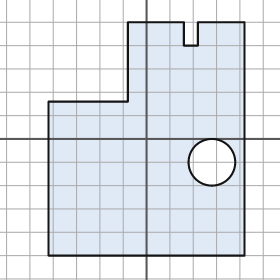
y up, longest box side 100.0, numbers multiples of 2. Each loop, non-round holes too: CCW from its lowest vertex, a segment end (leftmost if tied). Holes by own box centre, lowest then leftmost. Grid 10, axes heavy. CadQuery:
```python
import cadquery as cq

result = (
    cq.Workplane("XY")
    .moveTo(-42.0, -50.0)
    .lineTo(42.0, -50.0)
    .lineTo(42.0, 50.0)
    .lineTo(22.0, 50.0)
    .lineTo(22.0, 40.0)
    .lineTo(16.0, 40.0)
    .lineTo(16.0, 50.0)
    .lineTo(-8.0, 50.0)
    .lineTo(-8.0, 16.0)
    .lineTo(-42.0, 16.0)
    .close()
    .moveTo(28.0, -10.0)
    .circle(10.0)
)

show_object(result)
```